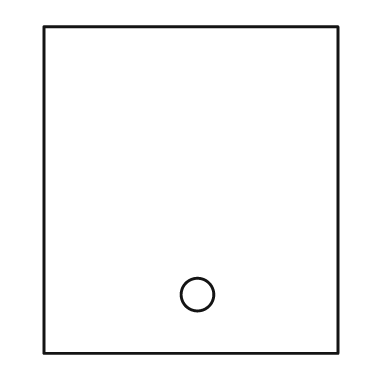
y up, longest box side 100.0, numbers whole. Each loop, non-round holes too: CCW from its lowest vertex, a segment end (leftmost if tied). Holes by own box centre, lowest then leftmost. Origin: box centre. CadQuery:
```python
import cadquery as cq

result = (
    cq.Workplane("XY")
    .moveTo(-45.0, -50.0)
    .lineTo(45.0, -50.0)
    .lineTo(45.0, 50.0)
    .lineTo(-45.0, 50.0)
    .close()
    .moveTo(2.0, -32.0)
    .circle(5.0)
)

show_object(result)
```